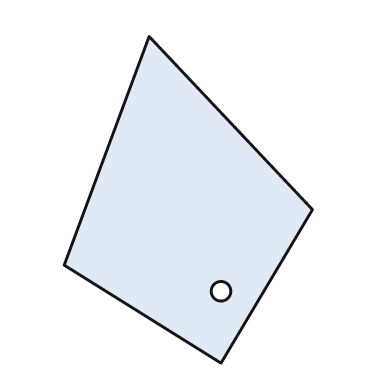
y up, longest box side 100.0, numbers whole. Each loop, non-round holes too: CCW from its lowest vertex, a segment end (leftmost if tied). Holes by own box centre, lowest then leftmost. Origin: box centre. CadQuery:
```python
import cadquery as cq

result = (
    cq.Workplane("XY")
    .moveTo(10.0, -50.0)
    .lineTo(38.0, -3.0)
    .lineTo(-12.0, 50.0)
    .lineTo(-38.0, -20.0)
    .close()
    .moveTo(10.0, -28.0)
    .circle(3.0)
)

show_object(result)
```